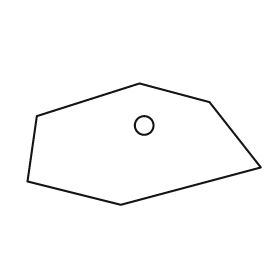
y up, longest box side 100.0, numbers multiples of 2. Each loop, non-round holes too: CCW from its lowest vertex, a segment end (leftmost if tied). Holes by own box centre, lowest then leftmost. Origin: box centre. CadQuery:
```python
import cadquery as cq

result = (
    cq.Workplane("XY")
    .moveTo(-10.0, -26.0)
    .lineTo(50.0, -10.0)
    .lineTo(28.0, 18.0)
    .lineTo(-2.0, 26.0)
    .lineTo(-46.0, 12.0)
    .lineTo(-50.0, -16.0)
    .close()
    .moveTo(0.0, 8.0)
    .circle(4.0)
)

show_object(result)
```